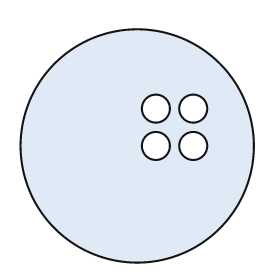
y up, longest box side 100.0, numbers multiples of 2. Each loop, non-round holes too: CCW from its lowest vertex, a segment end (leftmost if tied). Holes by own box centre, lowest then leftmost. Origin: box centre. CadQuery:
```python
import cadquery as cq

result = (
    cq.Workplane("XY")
    .moveTo(0.0, 0.0)
    .circle(50.0)
    .moveTo(8.0, 0.0)
    .circle(6.0)
    .moveTo(24.0, 0.0)
    .circle(6.0)
    .moveTo(8.0, 16.0)
    .circle(6.0)
    .moveTo(24.0, 16.0)
    .circle(6.0)
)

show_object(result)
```